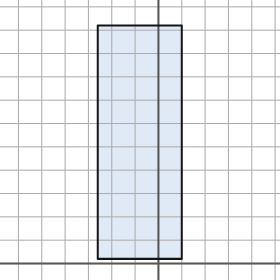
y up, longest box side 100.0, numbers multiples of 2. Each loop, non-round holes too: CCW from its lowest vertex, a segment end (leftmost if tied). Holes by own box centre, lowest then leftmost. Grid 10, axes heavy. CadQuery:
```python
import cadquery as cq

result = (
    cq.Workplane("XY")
    .moveTo(-26.0, 2.0)
    .lineTo(10.0, 2.0)
    .lineTo(10.0, 102.0)
    .lineTo(-26.0, 102.0)
    .close()
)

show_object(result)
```